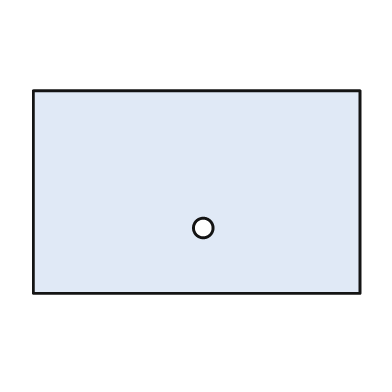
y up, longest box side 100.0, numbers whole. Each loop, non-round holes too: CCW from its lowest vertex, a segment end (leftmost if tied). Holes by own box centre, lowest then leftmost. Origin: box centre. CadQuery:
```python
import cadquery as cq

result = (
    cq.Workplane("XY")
    .moveTo(-50.0, -31.0)
    .lineTo(50.0, -31.0)
    .lineTo(50.0, 31.0)
    .lineTo(-50.0, 31.0)
    .close()
    .moveTo(2.0, -11.0)
    .circle(3.0)
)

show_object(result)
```